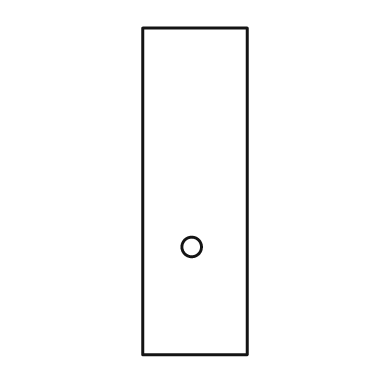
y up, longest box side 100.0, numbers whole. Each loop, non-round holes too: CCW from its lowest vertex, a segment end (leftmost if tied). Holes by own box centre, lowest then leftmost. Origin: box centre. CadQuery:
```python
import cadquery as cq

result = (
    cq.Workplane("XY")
    .moveTo(-16.0, -50.0)
    .lineTo(16.0, -50.0)
    .lineTo(16.0, 50.0)
    .lineTo(-16.0, 50.0)
    .close()
    .moveTo(-1.0, -17.0)
    .circle(3.0)
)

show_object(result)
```